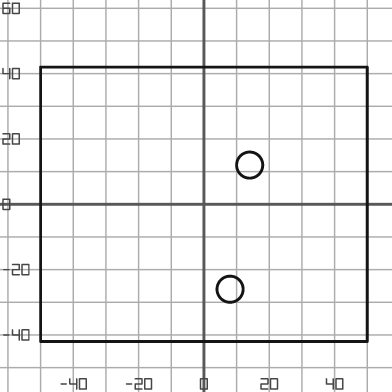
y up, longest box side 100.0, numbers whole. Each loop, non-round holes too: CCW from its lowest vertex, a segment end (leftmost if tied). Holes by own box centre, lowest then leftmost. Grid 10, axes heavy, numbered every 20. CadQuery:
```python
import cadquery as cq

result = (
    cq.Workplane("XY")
    .moveTo(-50.0, -42.0)
    .lineTo(50.0, -42.0)
    .lineTo(50.0, 42.0)
    .lineTo(-50.0, 42.0)
    .close()
    .moveTo(8.0, -26.0)
    .circle(4.0)
    .moveTo(14.0, 12.0)
    .circle(4.0)
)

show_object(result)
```